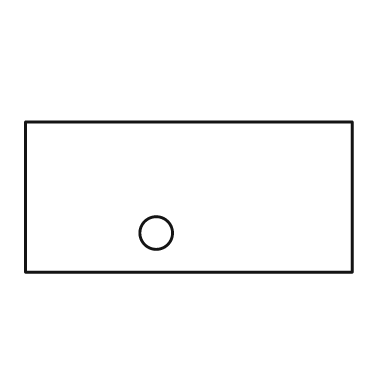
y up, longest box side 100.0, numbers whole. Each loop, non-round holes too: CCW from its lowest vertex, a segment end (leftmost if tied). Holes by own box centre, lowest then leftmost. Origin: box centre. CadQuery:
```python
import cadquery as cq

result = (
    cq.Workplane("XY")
    .moveTo(-50.0, -23.0)
    .lineTo(50.0, -23.0)
    .lineTo(50.0, 23.0)
    .lineTo(-50.0, 23.0)
    .close()
    .moveTo(-10.0, -11.0)
    .circle(5.0)
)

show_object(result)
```